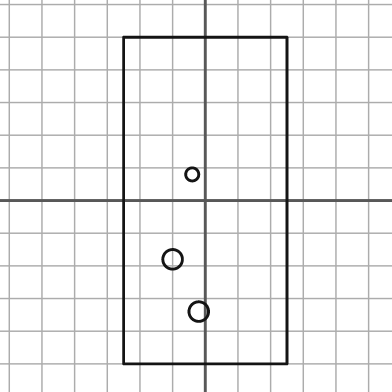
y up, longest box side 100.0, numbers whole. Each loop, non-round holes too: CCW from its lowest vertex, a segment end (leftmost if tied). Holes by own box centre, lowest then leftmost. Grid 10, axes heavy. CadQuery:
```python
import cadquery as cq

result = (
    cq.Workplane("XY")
    .moveTo(-25.0, -50.0)
    .lineTo(25.0, -50.0)
    .lineTo(25.0, 50.0)
    .lineTo(-25.0, 50.0)
    .close()
    .moveTo(-2.0, -34.0)
    .circle(3.0)
    .moveTo(-10.0, -18.0)
    .circle(3.0)
    .moveTo(-4.0, 8.0)
    .circle(2.0)
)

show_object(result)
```